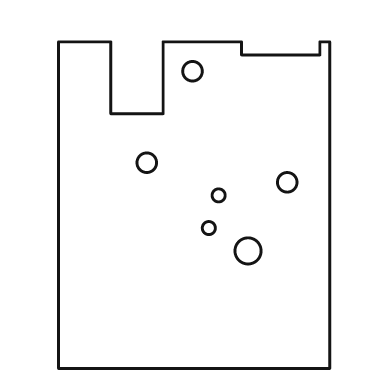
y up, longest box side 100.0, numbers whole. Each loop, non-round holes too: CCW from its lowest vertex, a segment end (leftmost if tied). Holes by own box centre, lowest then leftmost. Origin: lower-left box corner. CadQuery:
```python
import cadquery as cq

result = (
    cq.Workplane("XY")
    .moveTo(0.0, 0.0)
    .lineTo(83.0, 0.0)
    .lineTo(83.0, 100.0)
    .lineTo(80.0, 100.0)
    .lineTo(80.0, 96.0)
    .lineTo(56.0, 96.0)
    .lineTo(56.0, 100.0)
    .lineTo(32.0, 100.0)
    .lineTo(32.0, 78.0)
    .lineTo(16.0, 78.0)
    .lineTo(16.0, 100.0)
    .lineTo(0.0, 100.0)
    .close()
    .moveTo(58.0, 36.0)
    .circle(4.0)
    .moveTo(46.0, 43.0)
    .circle(2.0)
    .moveTo(49.0, 53.0)
    .circle(2.0)
    .moveTo(70.0, 57.0)
    .circle(3.0)
    .moveTo(27.0, 63.0)
    .circle(3.0)
    .moveTo(41.0, 91.0)
    .circle(3.0)
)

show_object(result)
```